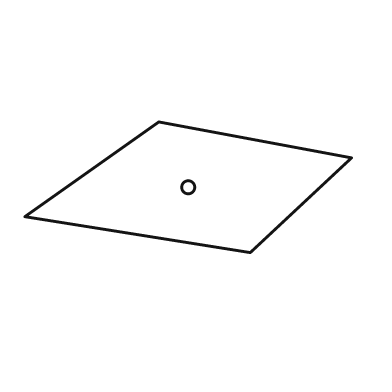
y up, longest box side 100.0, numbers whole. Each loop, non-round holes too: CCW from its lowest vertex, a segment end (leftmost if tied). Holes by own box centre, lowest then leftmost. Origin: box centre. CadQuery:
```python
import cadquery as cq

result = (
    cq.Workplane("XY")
    .moveTo(19.0, -20.0)
    .lineTo(50.0, 9.0)
    .lineTo(-9.0, 20.0)
    .lineTo(-50.0, -9.0)
    .close()
    .moveTo(0.0, 0.0)
    .circle(2.0)
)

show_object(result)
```